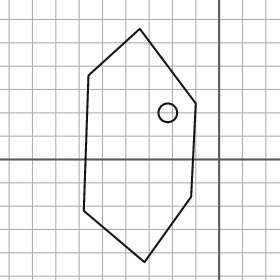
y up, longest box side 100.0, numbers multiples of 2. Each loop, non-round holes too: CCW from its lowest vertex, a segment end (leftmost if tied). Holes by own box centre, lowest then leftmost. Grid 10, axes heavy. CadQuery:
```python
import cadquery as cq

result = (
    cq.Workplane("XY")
    .moveTo(-32.0, -44.0)
    .lineTo(-12.0, -16.0)
    .lineTo(-10.0, 24.0)
    .lineTo(-34.0, 56.0)
    .lineTo(-56.0, 36.0)
    .lineTo(-58.0, -22.0)
    .close()
    .moveTo(-22.0, 20.0)
    .circle(4.0)
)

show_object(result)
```